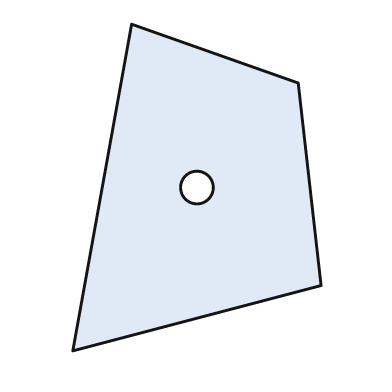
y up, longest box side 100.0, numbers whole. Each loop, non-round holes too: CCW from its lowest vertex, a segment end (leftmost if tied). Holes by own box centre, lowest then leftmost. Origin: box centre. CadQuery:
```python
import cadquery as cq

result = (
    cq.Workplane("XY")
    .moveTo(-38.0, -50.0)
    .lineTo(38.0, -30.0)
    .lineTo(31.0, 32.0)
    .lineTo(-20.0, 50.0)
    .close()
    .moveTo(0.0, 0.0)
    .circle(5.0)
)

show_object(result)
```